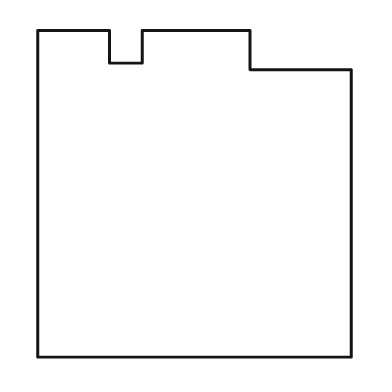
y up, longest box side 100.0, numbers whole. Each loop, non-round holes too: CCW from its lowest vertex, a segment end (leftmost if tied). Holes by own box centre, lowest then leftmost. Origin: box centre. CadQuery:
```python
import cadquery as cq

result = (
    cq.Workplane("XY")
    .moveTo(-48.0, -50.0)
    .lineTo(48.0, -50.0)
    .lineTo(48.0, 38.0)
    .lineTo(17.0, 38.0)
    .lineTo(17.0, 50.0)
    .lineTo(-16.0, 50.0)
    .lineTo(-16.0, 40.0)
    .lineTo(-26.0, 40.0)
    .lineTo(-26.0, 50.0)
    .lineTo(-48.0, 50.0)
    .close()
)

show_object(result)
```